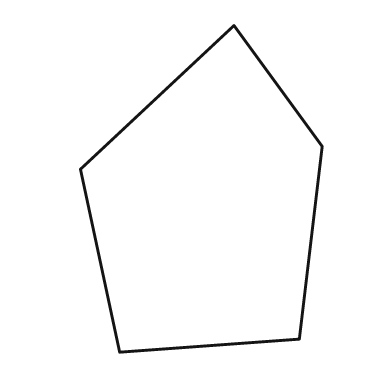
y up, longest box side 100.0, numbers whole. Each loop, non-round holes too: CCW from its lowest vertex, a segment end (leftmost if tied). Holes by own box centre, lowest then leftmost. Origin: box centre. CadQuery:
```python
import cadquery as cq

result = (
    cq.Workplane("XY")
    .moveTo(-25.0, -50.0)
    .lineTo(30.0, -46.0)
    .lineTo(37.0, 13.0)
    .lineTo(10.0, 50.0)
    .lineTo(-37.0, 6.0)
    .close()
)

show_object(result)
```